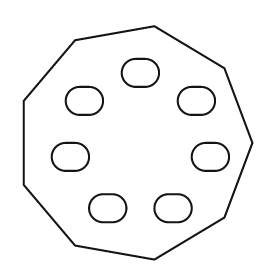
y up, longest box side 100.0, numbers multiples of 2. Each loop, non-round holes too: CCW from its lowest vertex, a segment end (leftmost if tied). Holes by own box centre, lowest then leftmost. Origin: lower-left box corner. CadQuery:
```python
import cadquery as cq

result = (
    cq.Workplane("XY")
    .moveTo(56.0, 0.0)
    .lineTo(86.0, 18.0)
    .lineTo(98.0, 50.0)
    .lineTo(86.0, 82.0)
    .lineTo(56.0, 100.0)
    .lineTo(22.0, 94.0)
    .lineTo(0.0, 68.0)
    .lineTo(0.0, 32.0)
    .lineTo(22.0, 6.0)
    .close()
    .moveTo(34.0, 16.0)
    .lineTo(38.0, 16.0)
    .threePointArc((44.0, 22.0), (38.0, 28.0))
    .lineTo(34.0, 28.0)
    .threePointArc((28.0, 22.0), (34.0, 16.0))
    .close()
    .moveTo(62.0, 16.0)
    .lineTo(66.0, 16.0)
    .threePointArc((72.0, 22.0), (66.0, 28.0))
    .lineTo(62.0, 28.0)
    .threePointArc((56.0, 22.0), (62.0, 16.0))
    .close()
    .moveTo(18.0, 38.0)
    .lineTo(22.0, 38.0)
    .threePointArc((28.0, 44.0), (22.0, 50.0))
    .lineTo(18.0, 50.0)
    .threePointArc((12.0, 44.0), (18.0, 38.0))
    .close()
    .moveTo(78.0, 38.0)
    .lineTo(82.0, 38.0)
    .threePointArc((88.0, 44.0), (82.0, 50.0))
    .lineTo(78.0, 50.0)
    .threePointArc((72.0, 44.0), (78.0, 38.0))
    .close()
    .moveTo(24.0, 62.0)
    .lineTo(28.0, 62.0)
    .threePointArc((34.0, 68.0), (28.0, 74.0))
    .lineTo(24.0, 74.0)
    .threePointArc((18.0, 68.0), (24.0, 62.0))
    .close()
    .moveTo(72.0, 62.0)
    .lineTo(76.0, 62.0)
    .threePointArc((82.0, 68.0), (76.0, 74.0))
    .lineTo(72.0, 74.0)
    .threePointArc((66.0, 68.0), (72.0, 62.0))
    .close()
    .moveTo(48.0, 74.0)
    .lineTo(52.0, 74.0)
    .threePointArc((58.0, 80.0), (52.0, 86.0))
    .lineTo(48.0, 86.0)
    .threePointArc((42.0, 80.0), (48.0, 74.0))
    .close()
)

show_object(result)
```